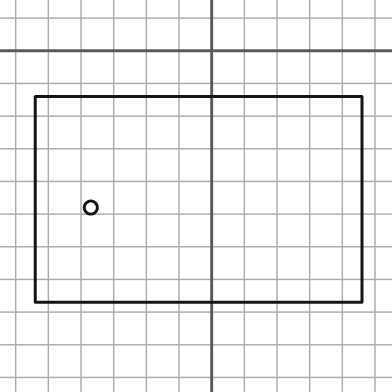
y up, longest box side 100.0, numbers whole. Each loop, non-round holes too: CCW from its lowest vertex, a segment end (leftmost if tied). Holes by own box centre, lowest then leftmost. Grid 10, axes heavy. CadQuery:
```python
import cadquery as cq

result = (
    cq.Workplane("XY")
    .moveTo(-54.0, -77.0)
    .lineTo(46.0, -77.0)
    .lineTo(46.0, -14.0)
    .lineTo(-54.0, -14.0)
    .close()
    .moveTo(-37.0, -48.0)
    .circle(2.0)
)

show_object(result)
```